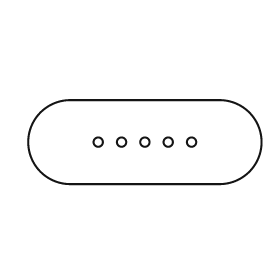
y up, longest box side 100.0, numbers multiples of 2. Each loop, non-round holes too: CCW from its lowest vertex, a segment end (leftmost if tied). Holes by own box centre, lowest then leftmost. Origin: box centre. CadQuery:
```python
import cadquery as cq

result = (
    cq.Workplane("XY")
    .moveTo(-32.0, -18.0)
    .lineTo(32.0, -18.0)
    .threePointArc((50.0, 0.0), (32.0, 18.0))
    .lineTo(-32.0, 18.0)
    .threePointArc((-50.0, 0.0), (-32.0, -18.0))
    .close()
    .moveTo(-20.0, 0.0)
    .circle(2.0)
    .moveTo(-10.0, 0.0)
    .circle(2.0)
    .moveTo(0.0, 0.0)
    .circle(2.0)
    .moveTo(10.0, 0.0)
    .circle(2.0)
    .moveTo(20.0, 0.0)
    .circle(2.0)
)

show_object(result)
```